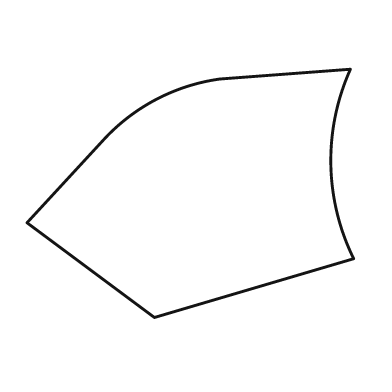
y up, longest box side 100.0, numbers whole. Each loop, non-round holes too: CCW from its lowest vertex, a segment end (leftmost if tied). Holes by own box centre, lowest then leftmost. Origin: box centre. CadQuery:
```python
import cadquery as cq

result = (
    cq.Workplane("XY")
    .moveTo(-11.0, -38.0)
    .lineTo(50.0, -20.0)
    .threePointArc((43.0, 9.0), (49.0, 38.0))
    .lineTo(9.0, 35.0)
    .threePointArc((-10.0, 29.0), (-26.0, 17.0))
    .lineTo(-50.0, -9.0)
    .close()
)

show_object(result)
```